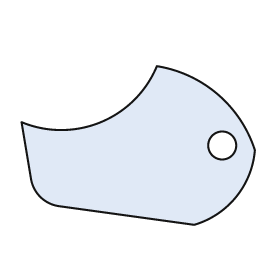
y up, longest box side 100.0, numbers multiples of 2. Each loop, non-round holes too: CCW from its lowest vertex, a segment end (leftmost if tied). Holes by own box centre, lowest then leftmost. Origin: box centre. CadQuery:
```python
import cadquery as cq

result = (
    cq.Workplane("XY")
    .moveTo(24.0, -34.0)
    .threePointArc((42.0, -22.0), (50.0, -2.0))
    .threePointArc((34.0, 22.0), (8.0, 34.0))
    .threePointArc((-16.0, 10.0), (-50.0, 10.0))
    .lineTo(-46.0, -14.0)
    .threePointArc((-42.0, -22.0), (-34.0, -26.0))
    .close()
    .moveTo(36.0, 0.0)
    .circle(6.0)
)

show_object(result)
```